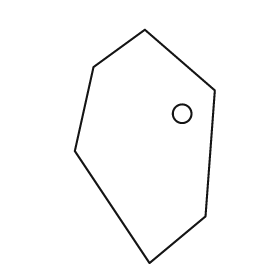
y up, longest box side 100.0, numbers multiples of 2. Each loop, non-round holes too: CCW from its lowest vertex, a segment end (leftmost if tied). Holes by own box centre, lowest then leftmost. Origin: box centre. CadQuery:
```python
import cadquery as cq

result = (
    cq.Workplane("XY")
    .moveTo(2.0, -50.0)
    .lineTo(26.0, -30.0)
    .lineTo(30.0, 24.0)
    .lineTo(0.0, 50.0)
    .lineTo(-22.0, 34.0)
    .lineTo(-30.0, -2.0)
    .close()
    .moveTo(16.0, 14.0)
    .circle(4.0)
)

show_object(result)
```